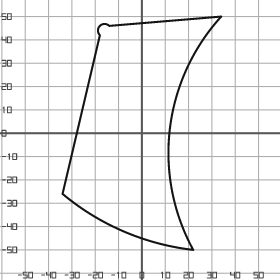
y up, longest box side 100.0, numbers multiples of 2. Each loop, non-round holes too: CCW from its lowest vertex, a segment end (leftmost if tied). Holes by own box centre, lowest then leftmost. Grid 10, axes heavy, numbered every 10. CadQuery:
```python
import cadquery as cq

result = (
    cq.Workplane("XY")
    .moveTo(22.0, -50.0)
    .threePointArc((12.0, 2.0), (34.0, 50.0))
    .lineTo(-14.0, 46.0)
    .threePointArc((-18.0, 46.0), (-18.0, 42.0))
    .lineTo(-34.0, -26.0)
    .threePointArc((-8.0, -42.0), (22.0, -50.0))
    .close()
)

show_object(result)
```